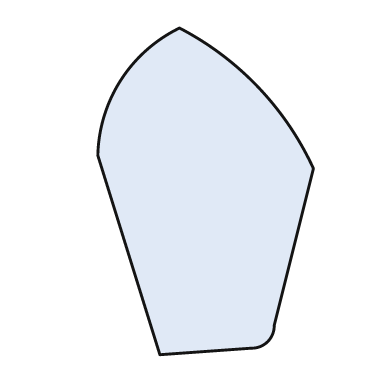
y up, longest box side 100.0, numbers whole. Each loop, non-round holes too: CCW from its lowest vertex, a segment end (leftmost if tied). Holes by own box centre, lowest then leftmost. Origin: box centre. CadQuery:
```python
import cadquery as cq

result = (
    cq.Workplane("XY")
    .moveTo(-14.0, -50.0)
    .lineTo(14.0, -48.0)
    .threePointArc((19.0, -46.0), (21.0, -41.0))
    .lineTo(33.0, 7.0)
    .threePointArc((16.0, 32.0), (-8.0, 50.0))
    .threePointArc((-26.0, 34.0), (-33.0, 11.0))
    .close()
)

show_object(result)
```